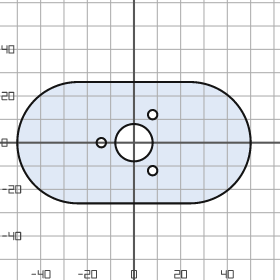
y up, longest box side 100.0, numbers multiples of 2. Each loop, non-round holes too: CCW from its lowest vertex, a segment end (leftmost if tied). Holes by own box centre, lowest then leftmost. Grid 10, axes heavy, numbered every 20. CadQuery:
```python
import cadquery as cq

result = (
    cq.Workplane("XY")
    .moveTo(-24.0, -26.0)
    .lineTo(24.0, -26.0)
    .threePointArc((50.0, 0.0), (24.0, 26.0))
    .lineTo(-24.0, 26.0)
    .threePointArc((-50.0, 0.0), (-24.0, -26.0))
    .close()
    .moveTo(8.0, -12.0)
    .circle(2.0)
    .moveTo(-14.0, 0.0)
    .circle(2.0)
    .moveTo(0.0, 0.0)
    .circle(8.0)
    .moveTo(8.0, 12.0)
    .circle(2.0)
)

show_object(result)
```